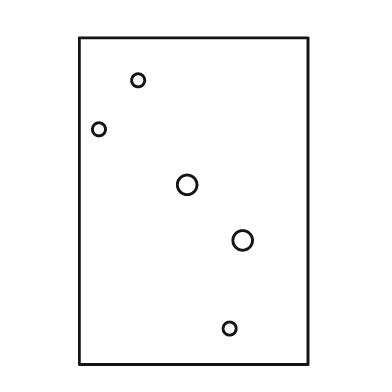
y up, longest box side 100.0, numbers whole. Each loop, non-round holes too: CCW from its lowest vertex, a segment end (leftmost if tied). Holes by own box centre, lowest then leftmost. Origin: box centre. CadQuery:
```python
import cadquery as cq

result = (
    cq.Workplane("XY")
    .moveTo(-35.0, -50.0)
    .lineTo(35.0, -50.0)
    .lineTo(35.0, 50.0)
    .lineTo(-35.0, 50.0)
    .close()
    .moveTo(11.0, -39.0)
    .circle(2.0)
    .moveTo(15.0, -12.0)
    .circle(3.0)
    .moveTo(-2.0, 5.0)
    .circle(3.0)
    .moveTo(-29.0, 22.0)
    .circle(2.0)
    .moveTo(-17.0, 37.0)
    .circle(2.0)
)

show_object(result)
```